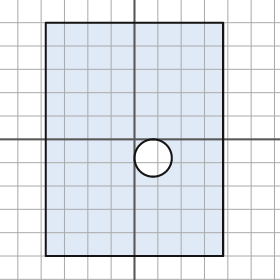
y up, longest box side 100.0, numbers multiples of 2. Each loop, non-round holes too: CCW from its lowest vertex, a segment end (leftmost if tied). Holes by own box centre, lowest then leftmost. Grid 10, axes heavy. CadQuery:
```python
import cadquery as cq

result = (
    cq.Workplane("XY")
    .moveTo(-38.0, -50.0)
    .lineTo(38.0, -50.0)
    .lineTo(38.0, 50.0)
    .lineTo(-38.0, 50.0)
    .close()
    .moveTo(8.0, -8.0)
    .circle(8.0)
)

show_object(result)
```